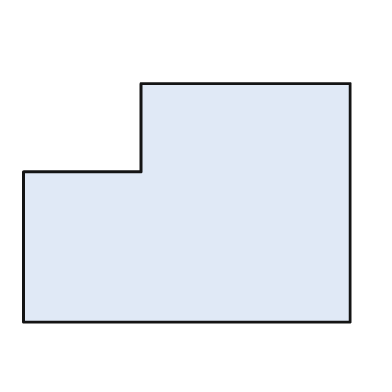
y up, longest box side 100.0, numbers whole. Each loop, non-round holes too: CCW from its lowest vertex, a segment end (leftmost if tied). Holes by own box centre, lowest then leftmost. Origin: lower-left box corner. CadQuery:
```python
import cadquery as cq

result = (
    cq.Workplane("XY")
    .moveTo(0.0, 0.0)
    .lineTo(100.0, 0.0)
    .lineTo(100.0, 73.0)
    .lineTo(36.0, 73.0)
    .lineTo(36.0, 46.0)
    .lineTo(0.0, 46.0)
    .close()
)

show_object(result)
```